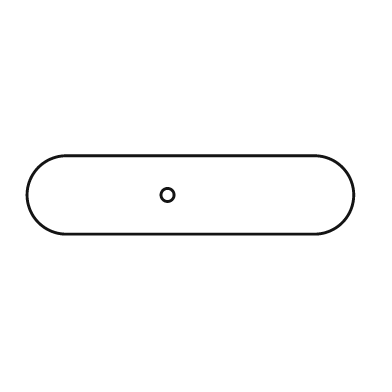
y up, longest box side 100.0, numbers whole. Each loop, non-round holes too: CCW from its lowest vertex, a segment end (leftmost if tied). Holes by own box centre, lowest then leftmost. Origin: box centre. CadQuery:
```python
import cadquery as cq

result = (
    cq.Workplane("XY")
    .moveTo(-38.0, -12.0)
    .lineTo(38.0, -12.0)
    .threePointArc((50.0, 0.0), (38.0, 12.0))
    .lineTo(-38.0, 12.0)
    .threePointArc((-50.0, 0.0), (-38.0, -12.0))
    .close()
    .moveTo(-7.0, 0.0)
    .circle(2.0)
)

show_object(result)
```